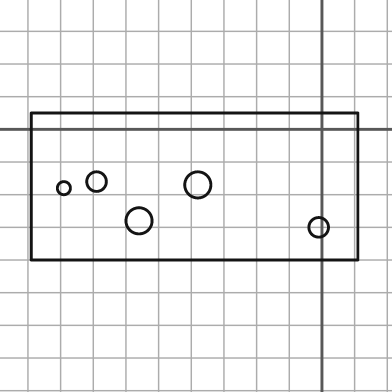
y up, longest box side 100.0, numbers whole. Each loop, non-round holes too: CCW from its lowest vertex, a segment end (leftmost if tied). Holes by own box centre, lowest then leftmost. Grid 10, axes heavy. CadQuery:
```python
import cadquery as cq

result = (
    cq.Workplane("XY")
    .moveTo(-89.0, -40.0)
    .lineTo(11.0, -40.0)
    .lineTo(11.0, 5.0)
    .lineTo(-89.0, 5.0)
    .close()
    .moveTo(-1.0, -30.0)
    .circle(3.0)
    .moveTo(-56.0, -28.0)
    .circle(4.0)
    .moveTo(-79.0, -18.0)
    .circle(2.0)
    .moveTo(-38.0, -17.0)
    .circle(4.0)
    .moveTo(-69.0, -16.0)
    .circle(3.0)
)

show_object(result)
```